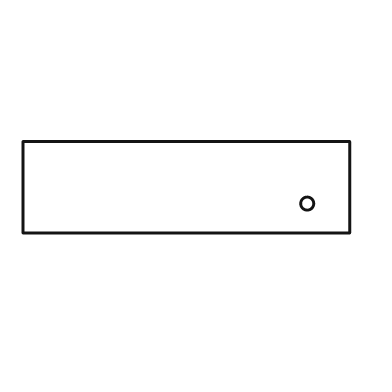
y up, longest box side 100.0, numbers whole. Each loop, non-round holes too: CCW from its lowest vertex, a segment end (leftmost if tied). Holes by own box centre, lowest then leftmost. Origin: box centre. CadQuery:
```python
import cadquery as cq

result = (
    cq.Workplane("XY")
    .moveTo(-50.0, -14.0)
    .lineTo(50.0, -14.0)
    .lineTo(50.0, 14.0)
    .lineTo(-50.0, 14.0)
    .close()
    .moveTo(37.0, -5.0)
    .circle(2.0)
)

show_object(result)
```